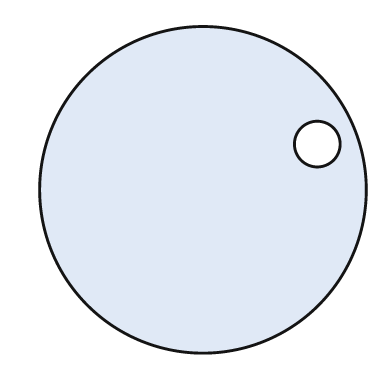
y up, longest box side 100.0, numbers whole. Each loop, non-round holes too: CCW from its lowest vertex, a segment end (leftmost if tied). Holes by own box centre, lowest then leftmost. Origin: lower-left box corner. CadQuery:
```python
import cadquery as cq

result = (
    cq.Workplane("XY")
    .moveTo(50.0, 50.0)
    .circle(50.0)
    .moveTo(85.0, 64.0)
    .circle(7.0)
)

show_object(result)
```